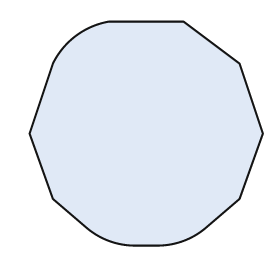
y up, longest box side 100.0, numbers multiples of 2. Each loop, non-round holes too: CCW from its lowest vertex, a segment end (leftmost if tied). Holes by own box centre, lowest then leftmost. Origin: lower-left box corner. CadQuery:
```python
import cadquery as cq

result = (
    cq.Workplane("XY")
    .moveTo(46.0, 0.0)
    .lineTo(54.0, 0.0)
    .threePointArc((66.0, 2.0), (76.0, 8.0))
    .lineTo(90.0, 20.0)
    .lineTo(100.0, 48.0)
    .lineTo(90.0, 78.0)
    .lineTo(66.0, 96.0)
    .lineTo(34.0, 96.0)
    .threePointArc((20.0, 90.0), (10.0, 78.0))
    .lineTo(0.0, 48.0)
    .lineTo(10.0, 20.0)
    .lineTo(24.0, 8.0)
    .threePointArc((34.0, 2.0), (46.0, 0.0))
    .close()
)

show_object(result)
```